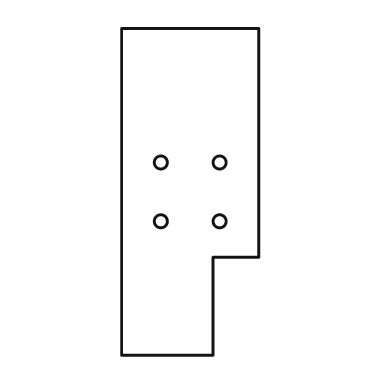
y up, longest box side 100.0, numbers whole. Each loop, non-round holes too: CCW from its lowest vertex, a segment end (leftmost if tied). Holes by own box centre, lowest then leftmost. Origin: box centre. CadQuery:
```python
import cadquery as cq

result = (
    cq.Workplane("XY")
    .moveTo(-21.0, -50.0)
    .lineTo(7.0, -50.0)
    .lineTo(7.0, -20.0)
    .lineTo(21.0, -20.0)
    .lineTo(21.0, 50.0)
    .lineTo(-21.0, 50.0)
    .close()
    .moveTo(-9.0, -9.0)
    .circle(2.0)
    .moveTo(9.0, -9.0)
    .circle(2.0)
    .moveTo(-9.0, 9.0)
    .circle(2.0)
    .moveTo(9.0, 9.0)
    .circle(2.0)
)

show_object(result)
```